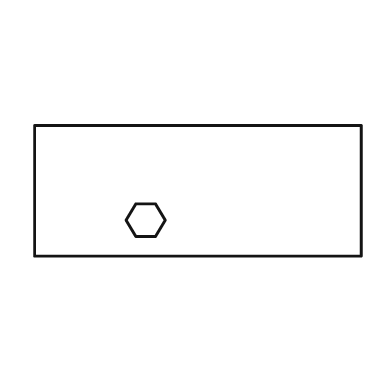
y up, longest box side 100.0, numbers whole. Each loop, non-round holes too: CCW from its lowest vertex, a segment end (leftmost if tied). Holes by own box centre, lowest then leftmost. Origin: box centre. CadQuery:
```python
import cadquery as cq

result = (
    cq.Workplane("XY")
    .moveTo(-50.0, -20.0)
    .lineTo(50.0, -20.0)
    .lineTo(50.0, 20.0)
    .lineTo(-50.0, 20.0)
    .close()
    .moveTo(-19.0, -14.0)
    .lineTo(-13.0, -14.0)
    .lineTo(-10.0, -9.0)
    .lineTo(-13.0, -4.0)
    .lineTo(-19.0, -4.0)
    .lineTo(-22.0, -9.0)
    .close()
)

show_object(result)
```